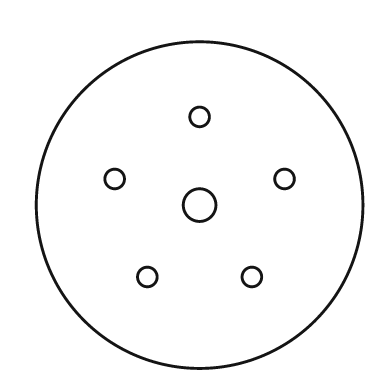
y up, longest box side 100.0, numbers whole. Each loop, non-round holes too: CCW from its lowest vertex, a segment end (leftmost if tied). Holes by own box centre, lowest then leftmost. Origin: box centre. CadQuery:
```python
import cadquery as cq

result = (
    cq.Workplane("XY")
    .moveTo(0.0, 0.0)
    .circle(50.0)
    .moveTo(-16.0, -22.0)
    .circle(3.0)
    .moveTo(16.0, -22.0)
    .circle(3.0)
    .moveTo(0.0, 0.0)
    .circle(5.0)
    .moveTo(-26.0, 8.0)
    .circle(3.0)
    .moveTo(26.0, 8.0)
    .circle(3.0)
    .moveTo(0.0, 27.0)
    .circle(3.0)
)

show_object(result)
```